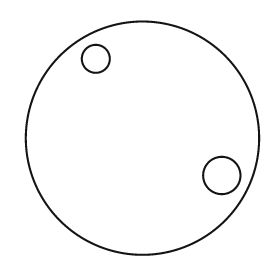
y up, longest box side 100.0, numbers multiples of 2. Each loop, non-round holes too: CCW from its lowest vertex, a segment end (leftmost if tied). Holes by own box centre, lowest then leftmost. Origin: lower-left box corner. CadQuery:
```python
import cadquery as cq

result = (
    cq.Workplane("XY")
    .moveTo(50.0, 50.0)
    .circle(50.0)
    .moveTo(84.0, 34.0)
    .circle(8.0)
    .moveTo(30.0, 84.0)
    .circle(6.0)
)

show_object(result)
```